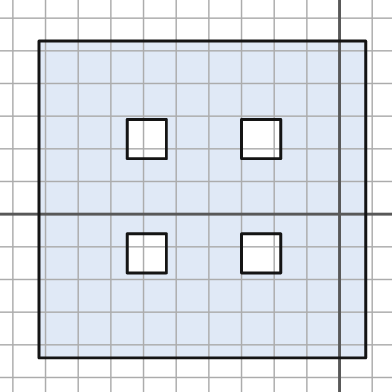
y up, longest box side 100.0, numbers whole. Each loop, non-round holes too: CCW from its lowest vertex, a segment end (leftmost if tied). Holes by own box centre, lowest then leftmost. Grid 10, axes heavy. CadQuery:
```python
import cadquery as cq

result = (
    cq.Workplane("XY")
    .moveTo(-92.0, -44.0)
    .lineTo(8.0, -44.0)
    .lineTo(8.0, 53.0)
    .lineTo(-92.0, 53.0)
    .close()
    .moveTo(-65.0, -18.0)
    .lineTo(-53.0, -18.0)
    .lineTo(-53.0, -6.0)
    .lineTo(-65.0, -6.0)
    .close()
    .moveTo(-30.0, -18.0)
    .lineTo(-18.0, -18.0)
    .lineTo(-18.0, -6.0)
    .lineTo(-30.0, -6.0)
    .close()
    .moveTo(-65.0, 17.0)
    .lineTo(-53.0, 17.0)
    .lineTo(-53.0, 29.0)
    .lineTo(-65.0, 29.0)
    .close()
    .moveTo(-30.0, 17.0)
    .lineTo(-18.0, 17.0)
    .lineTo(-18.0, 29.0)
    .lineTo(-30.0, 29.0)
    .close()
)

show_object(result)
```